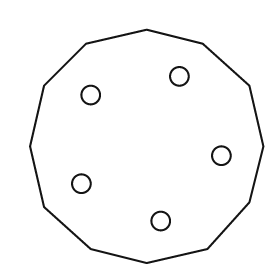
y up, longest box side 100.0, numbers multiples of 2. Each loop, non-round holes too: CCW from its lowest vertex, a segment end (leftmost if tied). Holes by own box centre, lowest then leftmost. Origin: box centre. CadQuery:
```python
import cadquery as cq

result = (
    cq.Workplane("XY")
    .moveTo(0.0, -50.0)
    .lineTo(26.0, -44.0)
    .lineTo(44.0, -24.0)
    .lineTo(50.0, 0.0)
    .lineTo(44.0, 26.0)
    .lineTo(24.0, 44.0)
    .lineTo(0.0, 50.0)
    .lineTo(-26.0, 44.0)
    .lineTo(-44.0, 26.0)
    .lineTo(-50.0, 0.0)
    .lineTo(-44.0, -26.0)
    .lineTo(-24.0, -44.0)
    .close()
    .moveTo(6.0, -32.0)
    .circle(4.0)
    .moveTo(-28.0, -16.0)
    .circle(4.0)
    .moveTo(32.0, -4.0)
    .circle(4.0)
    .moveTo(-24.0, 22.0)
    .circle(4.0)
    .moveTo(14.0, 30.0)
    .circle(4.0)
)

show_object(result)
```